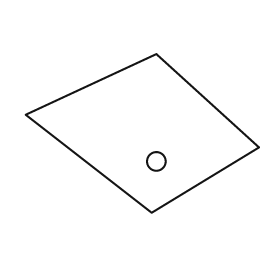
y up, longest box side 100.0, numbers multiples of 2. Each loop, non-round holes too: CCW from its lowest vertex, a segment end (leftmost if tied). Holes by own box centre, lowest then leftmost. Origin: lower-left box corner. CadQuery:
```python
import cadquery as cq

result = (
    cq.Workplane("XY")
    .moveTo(54.0, 0.0)
    .lineTo(100.0, 28.0)
    .lineTo(56.0, 68.0)
    .lineTo(0.0, 42.0)
    .close()
    .moveTo(56.0, 22.0)
    .circle(4.0)
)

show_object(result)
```